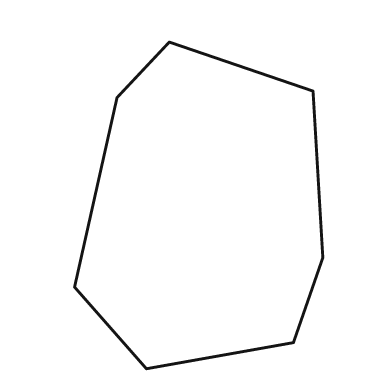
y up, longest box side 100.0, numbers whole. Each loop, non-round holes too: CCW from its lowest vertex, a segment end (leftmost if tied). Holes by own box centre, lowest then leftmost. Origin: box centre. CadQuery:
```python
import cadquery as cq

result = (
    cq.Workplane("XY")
    .moveTo(-16.0, -50.0)
    .lineTo(29.0, -42.0)
    .lineTo(38.0, -16.0)
    .lineTo(35.0, 35.0)
    .lineTo(-9.0, 50.0)
    .lineTo(-25.0, 33.0)
    .lineTo(-38.0, -25.0)
    .close()
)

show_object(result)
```